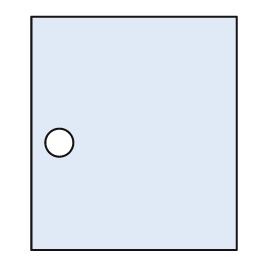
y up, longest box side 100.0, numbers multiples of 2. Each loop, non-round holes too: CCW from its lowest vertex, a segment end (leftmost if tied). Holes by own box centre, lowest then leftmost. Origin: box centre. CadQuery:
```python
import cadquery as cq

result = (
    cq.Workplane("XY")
    .moveTo(-44.0, -50.0)
    .lineTo(44.0, -50.0)
    .lineTo(44.0, 50.0)
    .lineTo(-44.0, 50.0)
    .close()
    .moveTo(-32.0, -4.0)
    .circle(6.0)
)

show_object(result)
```